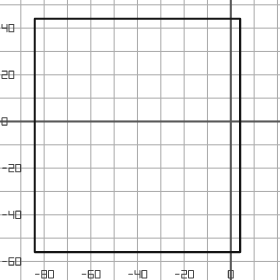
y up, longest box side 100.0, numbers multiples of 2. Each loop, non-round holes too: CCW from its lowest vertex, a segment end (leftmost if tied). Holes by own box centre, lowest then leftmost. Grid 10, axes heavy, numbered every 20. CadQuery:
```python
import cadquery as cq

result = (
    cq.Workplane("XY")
    .moveTo(-84.0, -56.0)
    .lineTo(4.0, -56.0)
    .lineTo(4.0, 44.0)
    .lineTo(-84.0, 44.0)
    .close()
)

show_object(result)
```